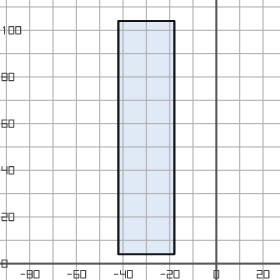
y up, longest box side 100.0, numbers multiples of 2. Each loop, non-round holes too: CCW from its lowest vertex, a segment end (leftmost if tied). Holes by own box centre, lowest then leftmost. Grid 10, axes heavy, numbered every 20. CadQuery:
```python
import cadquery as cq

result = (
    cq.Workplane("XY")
    .moveTo(-42.0, 4.0)
    .lineTo(-18.0, 4.0)
    .lineTo(-18.0, 104.0)
    .lineTo(-42.0, 104.0)
    .close()
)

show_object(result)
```